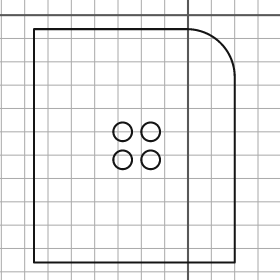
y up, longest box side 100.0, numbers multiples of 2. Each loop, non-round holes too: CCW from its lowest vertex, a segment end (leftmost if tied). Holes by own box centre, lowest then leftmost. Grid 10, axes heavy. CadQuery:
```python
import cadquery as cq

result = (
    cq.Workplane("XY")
    .moveTo(-66.0, -106.0)
    .lineTo(20.0, -106.0)
    .lineTo(20.0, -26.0)
    .threePointArc((14.0, -12.0), (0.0, -6.0))
    .lineTo(-66.0, -6.0)
    .close()
    .moveTo(-28.0, -62.0)
    .circle(4.0)
    .moveTo(-16.0, -62.0)
    .circle(4.0)
    .moveTo(-28.0, -50.0)
    .circle(4.0)
    .moveTo(-16.0, -50.0)
    .circle(4.0)
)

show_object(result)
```